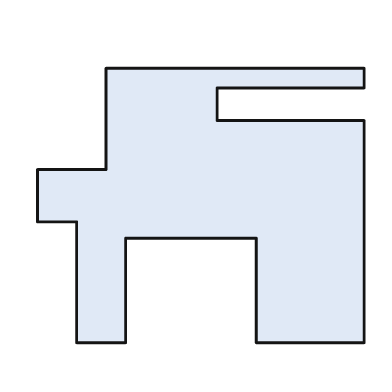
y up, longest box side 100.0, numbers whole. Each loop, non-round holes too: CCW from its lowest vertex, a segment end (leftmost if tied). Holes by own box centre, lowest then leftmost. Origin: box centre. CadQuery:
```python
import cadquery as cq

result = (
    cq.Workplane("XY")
    .moveTo(-38.0, -42.0)
    .lineTo(-23.0, -42.0)
    .lineTo(-23.0, -10.0)
    .lineTo(17.0, -10.0)
    .lineTo(17.0, -42.0)
    .lineTo(50.0, -42.0)
    .lineTo(50.0, 26.0)
    .lineTo(5.0, 26.0)
    .lineTo(5.0, 36.0)
    .lineTo(50.0, 36.0)
    .lineTo(50.0, 42.0)
    .lineTo(-29.0, 42.0)
    .lineTo(-29.0, 11.0)
    .lineTo(-50.0, 11.0)
    .lineTo(-50.0, -5.0)
    .lineTo(-38.0, -5.0)
    .close()
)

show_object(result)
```